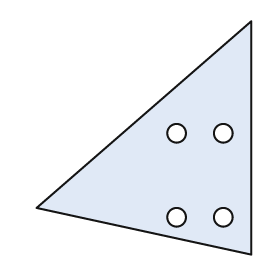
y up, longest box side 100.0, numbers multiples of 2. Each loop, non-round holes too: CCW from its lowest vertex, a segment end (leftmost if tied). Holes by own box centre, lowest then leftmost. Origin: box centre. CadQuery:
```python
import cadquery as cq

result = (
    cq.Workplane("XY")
    .moveTo(46.0, -50.0)
    .lineTo(46.0, 50.0)
    .lineTo(-46.0, -30.0)
    .close()
    .moveTo(14.0, -34.0)
    .circle(4.0)
    .moveTo(34.0, -34.0)
    .circle(4.0)
    .moveTo(14.0, 2.0)
    .circle(4.0)
    .moveTo(34.0, 2.0)
    .circle(4.0)
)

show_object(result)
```